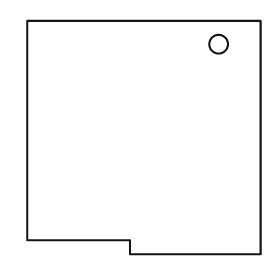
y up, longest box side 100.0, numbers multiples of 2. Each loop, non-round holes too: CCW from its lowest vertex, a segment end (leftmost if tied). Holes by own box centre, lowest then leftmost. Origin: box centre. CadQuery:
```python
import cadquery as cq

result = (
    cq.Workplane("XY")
    .moveTo(-6.0, -50.0)
    .lineTo(50.0, -50.0)
    .lineTo(50.0, 50.0)
    .lineTo(-50.0, 50.0)
    .lineTo(-50.0, -44.0)
    .lineTo(-6.0, -44.0)
    .close()
    .moveTo(32.0, 40.0)
    .circle(4.0)
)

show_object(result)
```